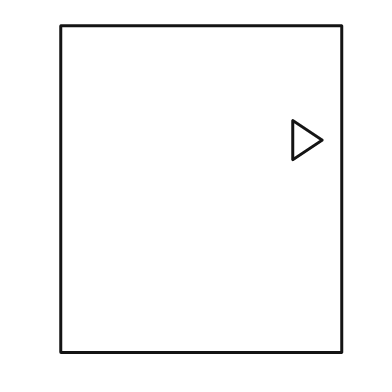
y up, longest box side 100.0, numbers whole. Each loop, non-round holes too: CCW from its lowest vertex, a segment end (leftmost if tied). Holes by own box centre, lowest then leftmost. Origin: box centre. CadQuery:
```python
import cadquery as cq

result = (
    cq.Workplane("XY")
    .moveTo(-43.0, -50.0)
    .lineTo(43.0, -50.0)
    .lineTo(43.0, 50.0)
    .lineTo(-43.0, 50.0)
    .close()
    .moveTo(28.0, 9.0)
    .lineTo(37.0, 15.0)
    .lineTo(28.0, 21.0)
    .close()
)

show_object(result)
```